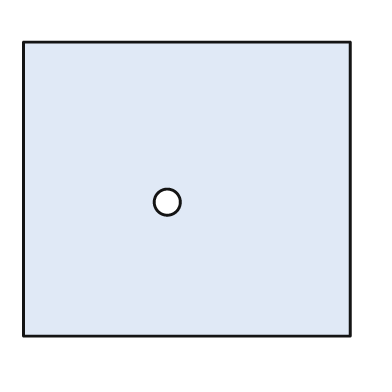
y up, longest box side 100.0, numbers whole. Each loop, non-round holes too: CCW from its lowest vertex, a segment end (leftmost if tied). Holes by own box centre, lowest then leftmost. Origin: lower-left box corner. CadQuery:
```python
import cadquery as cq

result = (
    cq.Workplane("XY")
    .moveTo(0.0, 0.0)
    .lineTo(100.0, 0.0)
    .lineTo(100.0, 90.0)
    .lineTo(0.0, 90.0)
    .close()
    .moveTo(44.0, 41.0)
    .circle(4.0)
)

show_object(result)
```